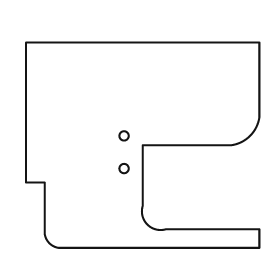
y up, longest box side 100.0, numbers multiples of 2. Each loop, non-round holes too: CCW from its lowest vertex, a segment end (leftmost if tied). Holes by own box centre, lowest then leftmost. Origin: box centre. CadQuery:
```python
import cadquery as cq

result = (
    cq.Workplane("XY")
    .moveTo(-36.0, -44.0)
    .lineTo(50.0, -44.0)
    .lineTo(50.0, -36.0)
    .lineTo(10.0, -36.0)
    .threePointArc((2.0, -34.0), (0.0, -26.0))
    .lineTo(0.0, 0.0)
    .lineTo(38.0, 0.0)
    .threePointArc((46.0, 4.0), (50.0, 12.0))
    .lineTo(50.0, 44.0)
    .lineTo(-50.0, 44.0)
    .lineTo(-50.0, -16.0)
    .lineTo(-42.0, -16.0)
    .lineTo(-42.0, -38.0)
    .threePointArc((-40.0, -42.0), (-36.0, -44.0))
    .close()
    .moveTo(-8.0, -10.0)
    .circle(2.0)
    .moveTo(-8.0, 4.0)
    .circle(2.0)
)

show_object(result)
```